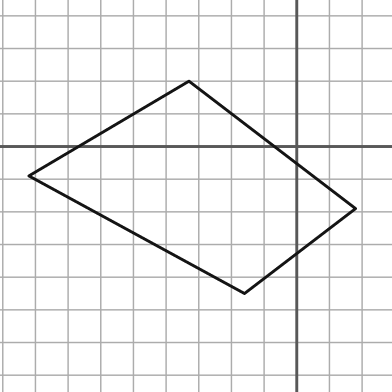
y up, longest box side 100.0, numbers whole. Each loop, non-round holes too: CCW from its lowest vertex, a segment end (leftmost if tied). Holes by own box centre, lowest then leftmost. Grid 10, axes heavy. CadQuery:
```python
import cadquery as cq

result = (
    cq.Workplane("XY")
    .moveTo(-16.0, -45.0)
    .lineTo(18.0, -19.0)
    .lineTo(-33.0, 20.0)
    .lineTo(-82.0, -9.0)
    .close()
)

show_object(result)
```